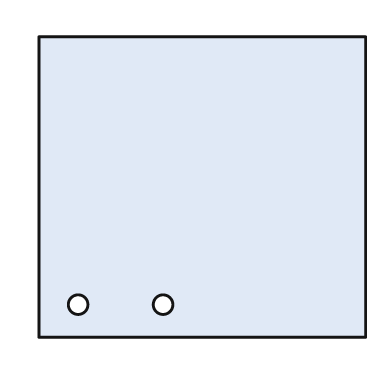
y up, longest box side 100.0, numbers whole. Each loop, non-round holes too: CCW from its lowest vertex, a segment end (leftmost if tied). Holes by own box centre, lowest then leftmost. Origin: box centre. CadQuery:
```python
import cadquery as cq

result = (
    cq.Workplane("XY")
    .moveTo(-50.0, -46.0)
    .lineTo(50.0, -46.0)
    .lineTo(50.0, 46.0)
    .lineTo(-50.0, 46.0)
    .close()
    .moveTo(-38.0, -36.0)
    .circle(3.0)
    .moveTo(-12.0, -36.0)
    .circle(3.0)
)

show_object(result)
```